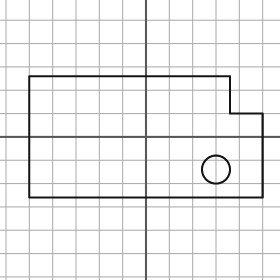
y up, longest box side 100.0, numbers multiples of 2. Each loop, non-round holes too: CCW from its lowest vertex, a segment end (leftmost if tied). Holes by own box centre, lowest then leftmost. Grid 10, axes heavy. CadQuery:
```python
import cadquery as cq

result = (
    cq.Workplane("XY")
    .moveTo(-50.0, -26.0)
    .lineTo(50.0, -26.0)
    .lineTo(50.0, 10.0)
    .lineTo(36.0, 10.0)
    .lineTo(36.0, 26.0)
    .lineTo(-50.0, 26.0)
    .close()
    .moveTo(30.0, -14.0)
    .circle(6.0)
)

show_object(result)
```